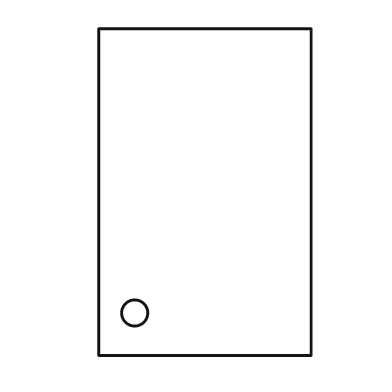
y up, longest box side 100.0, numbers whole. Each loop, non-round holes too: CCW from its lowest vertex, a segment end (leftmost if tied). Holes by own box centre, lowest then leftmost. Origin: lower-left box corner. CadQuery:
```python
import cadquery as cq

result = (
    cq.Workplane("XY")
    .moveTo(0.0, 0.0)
    .lineTo(65.0, 0.0)
    .lineTo(65.0, 100.0)
    .lineTo(0.0, 100.0)
    .close()
    .moveTo(11.0, 13.0)
    .circle(4.0)
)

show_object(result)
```